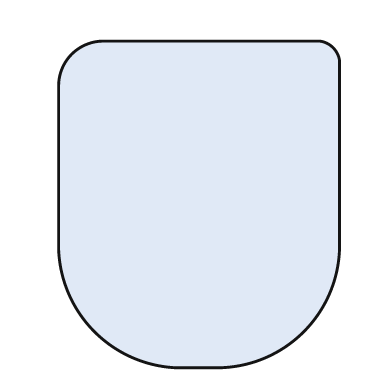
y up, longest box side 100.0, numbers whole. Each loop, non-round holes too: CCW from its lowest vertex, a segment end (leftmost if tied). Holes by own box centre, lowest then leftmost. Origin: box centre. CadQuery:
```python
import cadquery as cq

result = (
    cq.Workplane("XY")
    .moveTo(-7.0, -50.0)
    .lineTo(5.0, -50.0)
    .threePointArc((32.0, -39.0), (43.0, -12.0))
    .lineTo(43.0, 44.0)
    .threePointArc((41.0, 48.0), (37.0, 50.0))
    .lineTo(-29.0, 50.0)
    .threePointArc((-39.0, 46.0), (-43.0, 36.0))
    .lineTo(-43.0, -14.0)
    .threePointArc((-32.0, -39.0), (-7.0, -50.0))
    .close()
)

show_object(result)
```